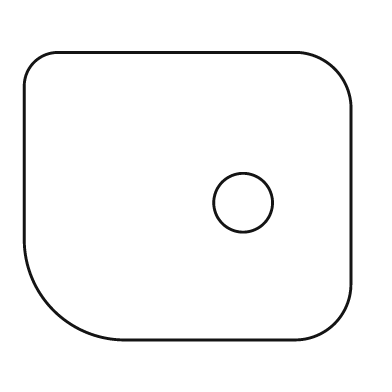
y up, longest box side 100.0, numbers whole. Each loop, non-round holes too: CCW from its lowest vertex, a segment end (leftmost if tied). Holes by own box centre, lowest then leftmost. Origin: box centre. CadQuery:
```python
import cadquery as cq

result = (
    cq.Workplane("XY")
    .moveTo(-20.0, -44.0)
    .lineTo(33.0, -44.0)
    .threePointArc((45.0, -39.0), (50.0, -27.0))
    .lineTo(50.0, 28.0)
    .threePointArc((45.0, 39.0), (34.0, 44.0))
    .lineTo(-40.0, 44.0)
    .threePointArc((-47.0, 41.0), (-50.0, 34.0))
    .lineTo(-50.0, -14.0)
    .threePointArc((-41.0, -35.0), (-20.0, -44.0))
    .close()
    .moveTo(17.0, -2.0)
    .circle(9.0)
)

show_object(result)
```